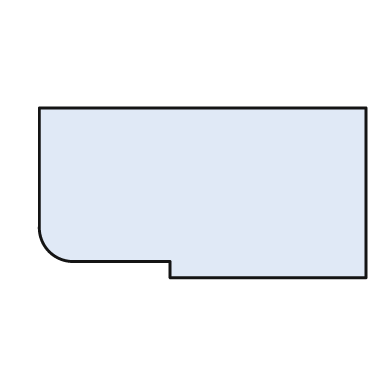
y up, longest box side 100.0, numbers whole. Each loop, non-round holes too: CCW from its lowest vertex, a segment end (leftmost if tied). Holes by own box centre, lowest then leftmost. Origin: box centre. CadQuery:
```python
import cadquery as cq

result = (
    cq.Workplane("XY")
    .moveTo(-10.0, -26.0)
    .lineTo(50.0, -26.0)
    .lineTo(50.0, 26.0)
    .lineTo(-50.0, 26.0)
    .lineTo(-50.0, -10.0)
    .threePointArc((-47.0, -18.0), (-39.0, -21.0))
    .lineTo(-10.0, -21.0)
    .close()
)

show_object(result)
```